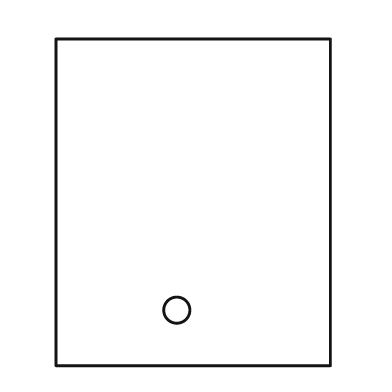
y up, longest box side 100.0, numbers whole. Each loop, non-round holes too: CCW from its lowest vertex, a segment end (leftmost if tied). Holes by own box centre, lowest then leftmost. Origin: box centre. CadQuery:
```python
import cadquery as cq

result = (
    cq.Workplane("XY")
    .moveTo(-42.0, -50.0)
    .lineTo(42.0, -50.0)
    .lineTo(42.0, 50.0)
    .lineTo(-42.0, 50.0)
    .close()
    .moveTo(-5.0, -33.0)
    .circle(4.0)
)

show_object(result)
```